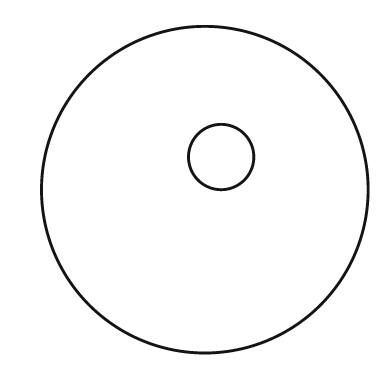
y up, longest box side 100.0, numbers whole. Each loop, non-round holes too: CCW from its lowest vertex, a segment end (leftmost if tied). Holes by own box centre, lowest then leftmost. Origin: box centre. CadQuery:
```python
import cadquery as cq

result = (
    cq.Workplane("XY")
    .moveTo(0.0, 0.0)
    .circle(50.0)
    .moveTo(5.0, 10.0)
    .circle(10.0)
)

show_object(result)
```